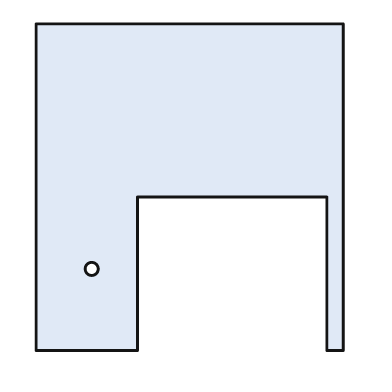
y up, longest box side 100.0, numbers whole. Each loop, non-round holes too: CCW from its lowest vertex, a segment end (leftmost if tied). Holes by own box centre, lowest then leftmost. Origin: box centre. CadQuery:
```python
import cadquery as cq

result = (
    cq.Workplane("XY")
    .moveTo(-47.0, -50.0)
    .lineTo(-16.0, -50.0)
    .lineTo(-16.0, -3.0)
    .lineTo(42.0, -3.0)
    .lineTo(42.0, -50.0)
    .lineTo(47.0, -50.0)
    .lineTo(47.0, 50.0)
    .lineTo(-47.0, 50.0)
    .close()
    .moveTo(-30.0, -25.0)
    .circle(2.0)
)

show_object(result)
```